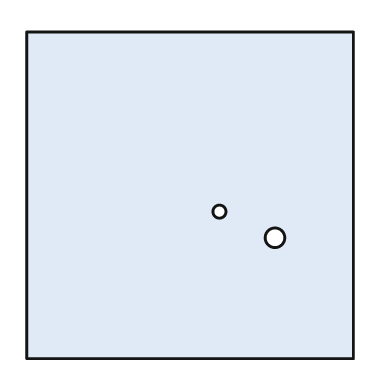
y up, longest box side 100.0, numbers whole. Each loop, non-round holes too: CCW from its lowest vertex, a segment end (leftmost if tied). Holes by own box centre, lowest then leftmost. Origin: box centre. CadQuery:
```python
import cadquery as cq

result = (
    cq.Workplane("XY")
    .moveTo(-50.0, -50.0)
    .lineTo(50.0, -50.0)
    .lineTo(50.0, 50.0)
    .lineTo(-50.0, 50.0)
    .close()
    .moveTo(26.0, -13.0)
    .circle(3.0)
    .moveTo(9.0, -5.0)
    .circle(2.0)
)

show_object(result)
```